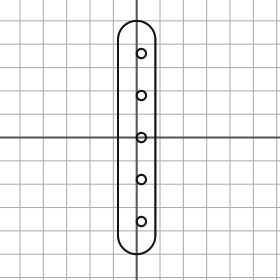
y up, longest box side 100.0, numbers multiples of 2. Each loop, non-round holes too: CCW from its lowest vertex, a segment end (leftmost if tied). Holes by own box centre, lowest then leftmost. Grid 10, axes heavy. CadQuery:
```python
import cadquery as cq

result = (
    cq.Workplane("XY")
    .moveTo(-8.0, -42.0)
    .threePointArc((0.0, -50.0), (8.0, -42.0))
    .lineTo(8.0, 42.0)
    .threePointArc((0.0, 50.0), (-8.0, 42.0))
    .close()
    .moveTo(2.0, -36.0)
    .circle(2.0)
    .moveTo(2.0, -18.0)
    .circle(2.0)
    .moveTo(2.0, 0.0)
    .circle(2.0)
    .moveTo(2.0, 18.0)
    .circle(2.0)
    .moveTo(2.0, 36.0)
    .circle(2.0)
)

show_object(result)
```